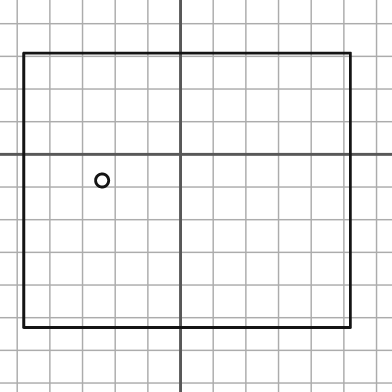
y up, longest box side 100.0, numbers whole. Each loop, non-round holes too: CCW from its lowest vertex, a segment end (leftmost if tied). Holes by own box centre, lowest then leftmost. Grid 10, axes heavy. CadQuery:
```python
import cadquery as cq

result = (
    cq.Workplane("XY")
    .moveTo(-48.0, -53.0)
    .lineTo(52.0, -53.0)
    .lineTo(52.0, 31.0)
    .lineTo(-48.0, 31.0)
    .close()
    .moveTo(-24.0, -8.0)
    .circle(2.0)
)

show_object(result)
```